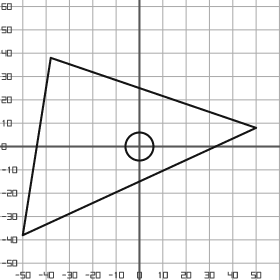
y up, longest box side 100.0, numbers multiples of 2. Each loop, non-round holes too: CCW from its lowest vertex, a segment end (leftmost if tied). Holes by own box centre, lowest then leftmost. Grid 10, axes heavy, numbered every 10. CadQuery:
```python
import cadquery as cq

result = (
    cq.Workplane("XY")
    .moveTo(-50.0, -38.0)
    .lineTo(50.0, 8.0)
    .lineTo(-38.0, 38.0)
    .close()
    .moveTo(0.0, 0.0)
    .circle(6.0)
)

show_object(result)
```